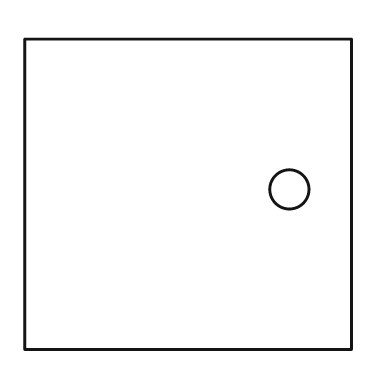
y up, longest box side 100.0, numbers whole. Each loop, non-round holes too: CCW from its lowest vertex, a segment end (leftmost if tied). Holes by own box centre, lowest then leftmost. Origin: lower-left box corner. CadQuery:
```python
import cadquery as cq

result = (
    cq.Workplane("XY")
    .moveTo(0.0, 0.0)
    .lineTo(100.0, 0.0)
    .lineTo(100.0, 95.0)
    .lineTo(0.0, 95.0)
    .close()
    .moveTo(81.0, 49.0)
    .circle(6.0)
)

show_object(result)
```